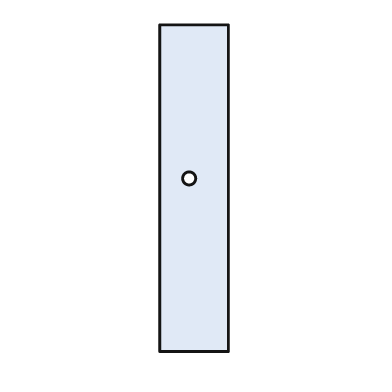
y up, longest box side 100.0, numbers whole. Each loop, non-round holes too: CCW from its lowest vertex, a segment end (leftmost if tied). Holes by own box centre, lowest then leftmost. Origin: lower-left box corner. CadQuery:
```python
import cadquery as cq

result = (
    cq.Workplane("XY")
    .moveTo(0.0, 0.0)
    .lineTo(21.0, 0.0)
    .lineTo(21.0, 100.0)
    .lineTo(0.0, 100.0)
    .close()
    .moveTo(9.0, 53.0)
    .circle(2.0)
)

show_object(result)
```